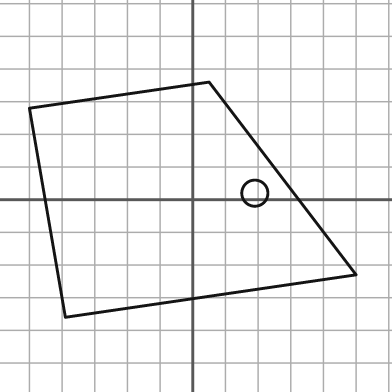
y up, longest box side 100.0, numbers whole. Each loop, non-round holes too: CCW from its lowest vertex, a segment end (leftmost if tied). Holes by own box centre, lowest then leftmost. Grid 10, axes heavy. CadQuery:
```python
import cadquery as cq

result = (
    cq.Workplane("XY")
    .moveTo(-39.0, -36.0)
    .lineTo(50.0, -23.0)
    .lineTo(5.0, 36.0)
    .lineTo(-50.0, 28.0)
    .close()
    .moveTo(19.0, 2.0)
    .circle(4.0)
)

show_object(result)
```